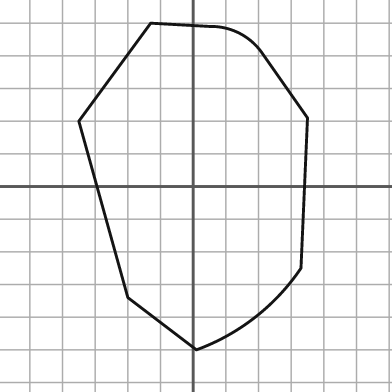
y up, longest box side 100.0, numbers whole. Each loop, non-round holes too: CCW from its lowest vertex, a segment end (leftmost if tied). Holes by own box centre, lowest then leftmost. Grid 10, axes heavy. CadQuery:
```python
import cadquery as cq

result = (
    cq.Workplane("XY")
    .moveTo(1.0, -50.0)
    .threePointArc((19.0, -40.0), (33.0, -25.0))
    .lineTo(35.0, 21.0)
    .lineTo(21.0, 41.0)
    .threePointArc((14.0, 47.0), (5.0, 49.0))
    .lineTo(-13.0, 50.0)
    .lineTo(-35.0, 20.0)
    .lineTo(-20.0, -34.0)
    .close()
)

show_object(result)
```